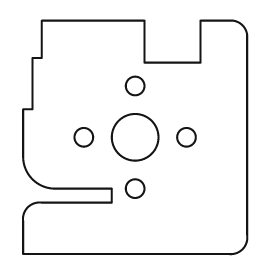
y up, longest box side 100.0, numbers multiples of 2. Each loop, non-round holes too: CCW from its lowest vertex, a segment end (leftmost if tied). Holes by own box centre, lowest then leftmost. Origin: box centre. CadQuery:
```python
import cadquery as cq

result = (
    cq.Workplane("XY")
    .moveTo(-48.0, -50.0)
    .lineTo(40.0, -50.0)
    .threePointArc((46.0, -48.0), (48.0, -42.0))
    .lineTo(48.0, 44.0)
    .threePointArc((46.0, 48.0), (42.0, 50.0))
    .lineTo(28.0, 50.0)
    .lineTo(28.0, 32.0)
    .lineTo(4.0, 32.0)
    .lineTo(4.0, 50.0)
    .lineTo(-40.0, 50.0)
    .lineTo(-40.0, 34.0)
    .lineTo(-44.0, 34.0)
    .lineTo(-44.0, 12.0)
    .lineTo(-48.0, 12.0)
    .lineTo(-48.0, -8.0)
    .threePointArc((-44.0, -18.0), (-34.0, -22.0))
    .lineTo(-10.0, -22.0)
    .lineTo(-10.0, -28.0)
    .lineTo(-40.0, -28.0)
    .threePointArc((-46.0, -30.0), (-48.0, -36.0))
    .close()
    .moveTo(0.0, -22.0)
    .circle(4.0)
    .moveTo(-22.0, 0.0)
    .circle(4.0)
    .moveTo(0.0, 0.0)
    .circle(10.0)
    .moveTo(22.0, 0.0)
    .circle(4.0)
    .moveTo(0.0, 22.0)
    .circle(4.0)
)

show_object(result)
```